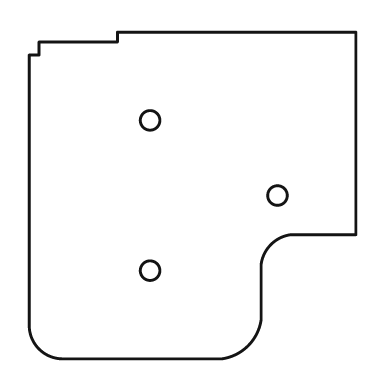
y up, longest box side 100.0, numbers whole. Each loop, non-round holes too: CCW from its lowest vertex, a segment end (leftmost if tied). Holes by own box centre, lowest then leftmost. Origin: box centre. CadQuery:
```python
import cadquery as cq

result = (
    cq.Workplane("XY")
    .moveTo(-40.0, -50.0)
    .lineTo(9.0, -50.0)
    .threePointArc((17.0, -46.0), (21.0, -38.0))
    .lineTo(21.0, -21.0)
    .threePointArc((24.0, -15.0), (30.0, -12.0))
    .lineTo(50.0, -12.0)
    .lineTo(50.0, 50.0)
    .lineTo(-23.0, 50.0)
    .lineTo(-23.0, 47.0)
    .lineTo(-47.0, 47.0)
    .lineTo(-47.0, 43.0)
    .lineTo(-50.0, 43.0)
    .lineTo(-50.0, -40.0)
    .threePointArc((-47.0, -47.0), (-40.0, -50.0))
    .close()
    .moveTo(-13.0, -23.0)
    .circle(3.0)
    .moveTo(26.0, 0.0)
    .circle(3.0)
    .moveTo(-13.0, 23.0)
    .circle(3.0)
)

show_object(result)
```